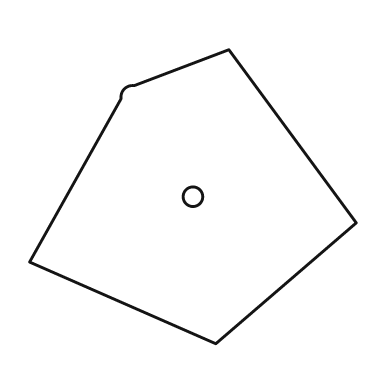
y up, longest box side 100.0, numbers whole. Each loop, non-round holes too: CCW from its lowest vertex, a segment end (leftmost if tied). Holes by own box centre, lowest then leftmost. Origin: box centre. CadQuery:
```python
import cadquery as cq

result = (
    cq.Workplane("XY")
    .moveTo(7.0, -45.0)
    .lineTo(50.0, -8.0)
    .lineTo(11.0, 45.0)
    .lineTo(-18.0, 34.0)
    .threePointArc((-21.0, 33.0), (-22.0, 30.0))
    .lineTo(-50.0, -20.0)
    .close()
    .moveTo(0.0, 0.0)
    .circle(3.0)
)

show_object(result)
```